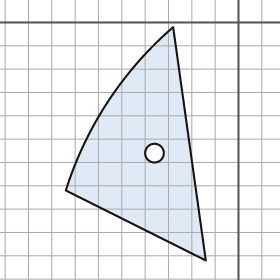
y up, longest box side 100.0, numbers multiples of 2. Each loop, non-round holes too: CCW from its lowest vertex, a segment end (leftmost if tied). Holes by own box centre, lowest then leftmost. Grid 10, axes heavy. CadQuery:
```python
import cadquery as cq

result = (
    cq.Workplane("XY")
    .moveTo(-14.0, -102.0)
    .lineTo(-28.0, -2.0)
    .threePointArc((-56.0, -34.0), (-74.0, -72.0))
    .close()
    .moveTo(-36.0, -56.0)
    .circle(4.0)
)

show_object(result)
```